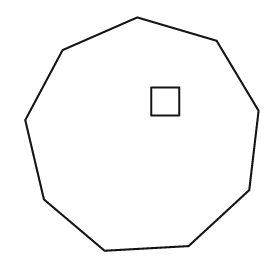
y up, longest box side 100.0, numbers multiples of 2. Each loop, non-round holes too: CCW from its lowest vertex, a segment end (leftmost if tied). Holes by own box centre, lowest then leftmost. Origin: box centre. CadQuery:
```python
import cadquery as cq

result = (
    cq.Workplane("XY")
    .moveTo(-16.0, -50.0)
    .lineTo(20.0, -48.0)
    .lineTo(46.0, -24.0)
    .lineTo(50.0, 10.0)
    .lineTo(32.0, 40.0)
    .lineTo(-2.0, 50.0)
    .lineTo(-34.0, 36.0)
    .lineTo(-50.0, 6.0)
    .lineTo(-42.0, -28.0)
    .close()
    .moveTo(4.0, 8.0)
    .lineTo(16.0, 8.0)
    .lineTo(16.0, 20.0)
    .lineTo(4.0, 20.0)
    .close()
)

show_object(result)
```